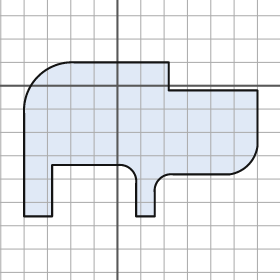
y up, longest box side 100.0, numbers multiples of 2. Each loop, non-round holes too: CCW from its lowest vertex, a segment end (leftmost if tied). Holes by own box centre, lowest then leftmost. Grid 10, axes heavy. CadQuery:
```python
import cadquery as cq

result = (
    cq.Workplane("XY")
    .moveTo(-40.0, -56.0)
    .lineTo(-28.0, -56.0)
    .lineTo(-28.0, -34.0)
    .lineTo(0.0, -34.0)
    .threePointArc((6.0, -36.0), (8.0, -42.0))
    .lineTo(8.0, -56.0)
    .lineTo(16.0, -56.0)
    .lineTo(16.0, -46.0)
    .threePointArc((18.0, -40.0), (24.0, -38.0))
    .lineTo(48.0, -38.0)
    .threePointArc((56.0, -34.0), (60.0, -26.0))
    .lineTo(60.0, -2.0)
    .lineTo(22.0, -2.0)
    .lineTo(22.0, 10.0)
    .lineTo(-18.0, 10.0)
    .threePointArc((-34.0, 4.0), (-40.0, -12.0))
    .close()
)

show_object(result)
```